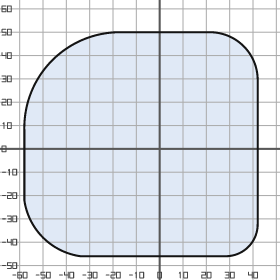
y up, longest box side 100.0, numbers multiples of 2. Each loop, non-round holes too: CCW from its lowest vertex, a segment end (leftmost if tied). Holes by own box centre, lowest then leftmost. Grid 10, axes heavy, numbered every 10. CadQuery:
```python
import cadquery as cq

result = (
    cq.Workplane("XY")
    .moveTo(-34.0, -46.0)
    .lineTo(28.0, -46.0)
    .threePointArc((38.0, -42.0), (42.0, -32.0))
    .lineTo(42.0, 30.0)
    .threePointArc((36.0, 44.0), (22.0, 50.0))
    .lineTo(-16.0, 50.0)
    .threePointArc((-46.0, 38.0), (-58.0, 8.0))
    .lineTo(-58.0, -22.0)
    .threePointArc((-50.0, -38.0), (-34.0, -46.0))
    .close()
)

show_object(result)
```